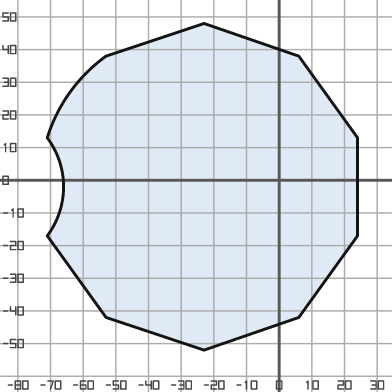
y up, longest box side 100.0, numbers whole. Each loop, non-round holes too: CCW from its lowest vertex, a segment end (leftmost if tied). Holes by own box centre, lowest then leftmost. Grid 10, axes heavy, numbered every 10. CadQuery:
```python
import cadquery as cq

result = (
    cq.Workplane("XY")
    .moveTo(-23.0, -52.0)
    .lineTo(6.0, -42.0)
    .lineTo(24.0, -17.0)
    .lineTo(24.0, 13.0)
    .lineTo(6.0, 38.0)
    .lineTo(-23.0, 48.0)
    .lineTo(-53.0, 38.0)
    .threePointArc((-64.0, 27.0), (-71.0, 13.0))
    .threePointArc((-66.0, -2.0), (-71.0, -17.0))
    .lineTo(-53.0, -42.0)
    .close()
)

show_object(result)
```